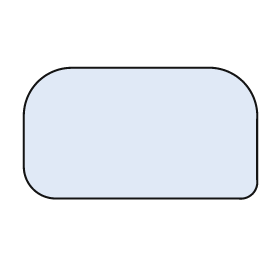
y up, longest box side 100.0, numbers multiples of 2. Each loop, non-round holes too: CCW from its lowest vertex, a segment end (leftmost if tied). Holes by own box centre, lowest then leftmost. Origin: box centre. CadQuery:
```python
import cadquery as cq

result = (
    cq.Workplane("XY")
    .moveTo(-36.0, -28.0)
    .lineTo(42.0, -28.0)
    .threePointArc((48.0, -26.0), (50.0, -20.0))
    .lineTo(50.0, 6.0)
    .threePointArc((44.0, 22.0), (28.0, 28.0))
    .lineTo(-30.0, 28.0)
    .threePointArc((-44.0, 22.0), (-50.0, 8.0))
    .lineTo(-50.0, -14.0)
    .threePointArc((-46.0, -24.0), (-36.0, -28.0))
    .close()
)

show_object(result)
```